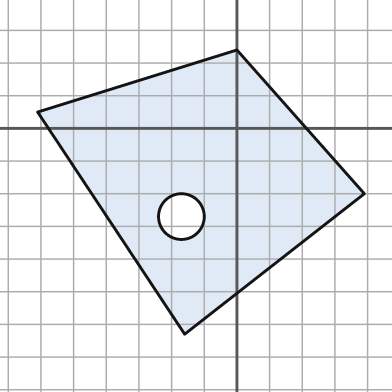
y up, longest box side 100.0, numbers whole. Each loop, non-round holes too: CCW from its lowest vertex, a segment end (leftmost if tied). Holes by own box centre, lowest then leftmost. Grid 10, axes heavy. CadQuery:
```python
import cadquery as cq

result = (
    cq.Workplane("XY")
    .moveTo(-16.0, -63.0)
    .lineTo(39.0, -20.0)
    .lineTo(0.0, 24.0)
    .lineTo(-61.0, 5.0)
    .close()
    .moveTo(-17.0, -27.0)
    .circle(7.0)
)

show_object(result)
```